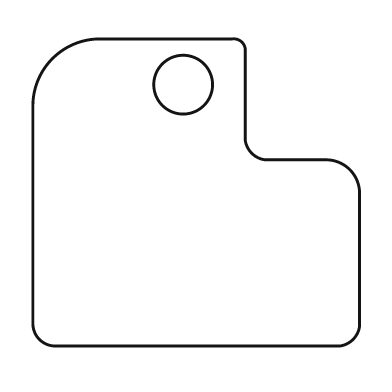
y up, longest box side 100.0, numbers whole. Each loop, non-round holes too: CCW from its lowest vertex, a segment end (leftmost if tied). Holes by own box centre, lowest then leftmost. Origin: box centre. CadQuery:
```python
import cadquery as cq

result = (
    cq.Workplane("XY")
    .moveTo(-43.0, -47.0)
    .lineTo(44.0, -47.0)
    .threePointArc((48.0, -45.0), (50.0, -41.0))
    .lineTo(50.0, 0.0)
    .threePointArc((47.0, 7.0), (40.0, 10.0))
    .lineTo(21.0, 10.0)
    .threePointArc((17.0, 12.0), (15.0, 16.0))
    .lineTo(15.0, 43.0)
    .threePointArc((14.0, 46.0), (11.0, 47.0))
    .lineTo(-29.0, 47.0)
    .threePointArc((-44.0, 41.0), (-50.0, 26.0))
    .lineTo(-50.0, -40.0)
    .threePointArc((-48.0, -45.0), (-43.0, -47.0))
    .close()
    .moveTo(-4.0, 33.0)
    .circle(9.0)
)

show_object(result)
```